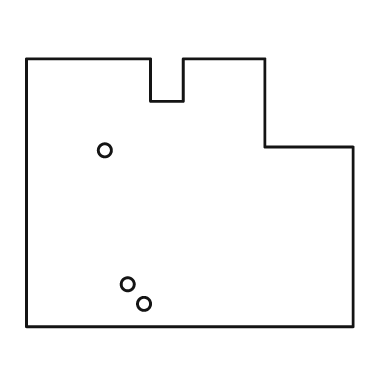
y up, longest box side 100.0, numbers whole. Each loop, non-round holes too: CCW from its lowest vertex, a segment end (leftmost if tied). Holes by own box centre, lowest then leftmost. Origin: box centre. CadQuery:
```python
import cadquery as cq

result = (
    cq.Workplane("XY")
    .moveTo(-50.0, -41.0)
    .lineTo(50.0, -41.0)
    .lineTo(50.0, 14.0)
    .lineTo(23.0, 14.0)
    .lineTo(23.0, 41.0)
    .lineTo(-2.0, 41.0)
    .lineTo(-2.0, 28.0)
    .lineTo(-12.0, 28.0)
    .lineTo(-12.0, 41.0)
    .lineTo(-50.0, 41.0)
    .close()
    .moveTo(-14.0, -34.0)
    .circle(2.0)
    .moveTo(-19.0, -28.0)
    .circle(2.0)
    .moveTo(-26.0, 13.0)
    .circle(2.0)
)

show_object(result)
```